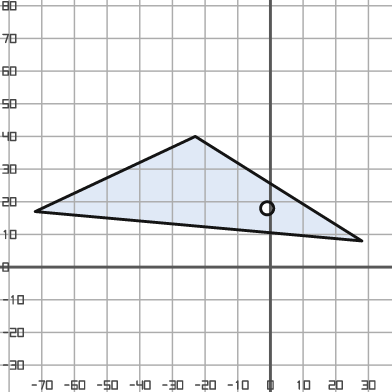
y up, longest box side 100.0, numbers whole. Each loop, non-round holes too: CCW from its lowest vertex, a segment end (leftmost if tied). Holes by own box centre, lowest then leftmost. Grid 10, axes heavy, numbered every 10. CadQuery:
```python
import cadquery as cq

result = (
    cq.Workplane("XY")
    .moveTo(28.0, 8.0)
    .lineTo(-23.0, 40.0)
    .lineTo(-72.0, 17.0)
    .close()
    .moveTo(-1.0, 18.0)
    .circle(2.0)
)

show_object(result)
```